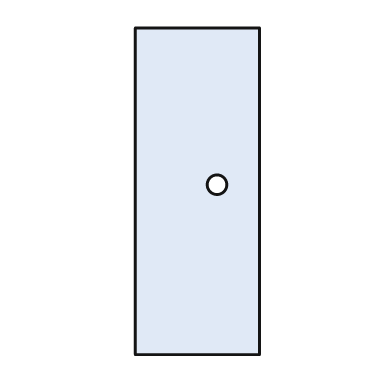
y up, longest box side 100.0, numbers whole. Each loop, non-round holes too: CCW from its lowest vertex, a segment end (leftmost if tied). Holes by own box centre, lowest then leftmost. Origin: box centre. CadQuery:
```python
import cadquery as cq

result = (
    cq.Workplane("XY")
    .moveTo(-19.0, -50.0)
    .lineTo(19.0, -50.0)
    .lineTo(19.0, 50.0)
    .lineTo(-19.0, 50.0)
    .close()
    .moveTo(6.0, 2.0)
    .circle(3.0)
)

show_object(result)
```